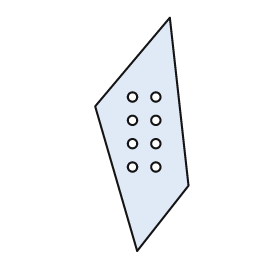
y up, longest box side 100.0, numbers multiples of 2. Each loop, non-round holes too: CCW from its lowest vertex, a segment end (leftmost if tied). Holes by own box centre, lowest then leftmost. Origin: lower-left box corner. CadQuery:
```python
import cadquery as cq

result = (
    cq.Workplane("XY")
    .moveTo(18.0, 0.0)
    .lineTo(40.0, 28.0)
    .lineTo(32.0, 100.0)
    .lineTo(0.0, 62.0)
    .close()
    .moveTo(16.0, 36.0)
    .circle(2.0)
    .moveTo(26.0, 36.0)
    .circle(2.0)
    .moveTo(16.0, 46.0)
    .circle(2.0)
    .moveTo(26.0, 46.0)
    .circle(2.0)
    .moveTo(16.0, 56.0)
    .circle(2.0)
    .moveTo(26.0, 56.0)
    .circle(2.0)
    .moveTo(16.0, 66.0)
    .circle(2.0)
    .moveTo(26.0, 66.0)
    .circle(2.0)
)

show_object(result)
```